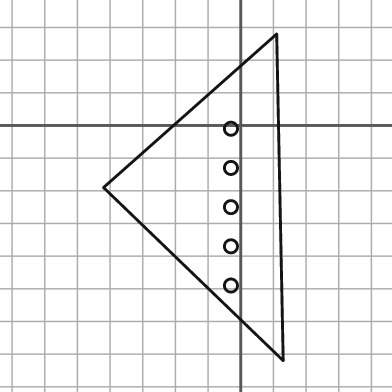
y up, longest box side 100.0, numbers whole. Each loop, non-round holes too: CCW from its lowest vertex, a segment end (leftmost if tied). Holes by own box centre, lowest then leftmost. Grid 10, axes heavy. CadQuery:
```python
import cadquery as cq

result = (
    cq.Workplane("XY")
    .moveTo(13.0, -72.0)
    .lineTo(11.0, 28.0)
    .lineTo(-42.0, -19.0)
    .close()
    .moveTo(-3.0, -49.0)
    .circle(2.0)
    .moveTo(-3.0, -37.0)
    .circle(2.0)
    .moveTo(-3.0, -25.0)
    .circle(2.0)
    .moveTo(-3.0, -13.0)
    .circle(2.0)
    .moveTo(-3.0, -1.0)
    .circle(2.0)
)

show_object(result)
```